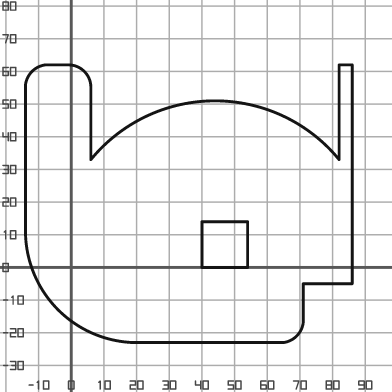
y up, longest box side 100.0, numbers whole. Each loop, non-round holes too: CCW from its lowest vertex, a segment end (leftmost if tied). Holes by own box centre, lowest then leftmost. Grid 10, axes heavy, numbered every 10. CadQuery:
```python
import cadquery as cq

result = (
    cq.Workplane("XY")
    .moveTo(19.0, -23.0)
    .lineTo(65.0, -23.0)
    .threePointArc((69.0, -21.0), (71.0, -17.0))
    .lineTo(71.0, -5.0)
    .lineTo(86.0, -5.0)
    .lineTo(86.0, 62.0)
    .lineTo(82.0, 62.0)
    .lineTo(82.0, 33.0)
    .threePointArc((44.0, 51.0), (6.0, 33.0))
    .lineTo(6.0, 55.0)
    .threePointArc((4.0, 60.0), (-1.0, 62.0))
    .lineTo(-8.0, 62.0)
    .threePointArc((-12.0, 60.0), (-14.0, 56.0))
    .lineTo(-14.0, 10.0)
    .threePointArc((-4.0, -13.0), (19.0, -23.0))
    .close()
    .moveTo(40.0, 0.0)
    .lineTo(54.0, 0.0)
    .lineTo(54.0, 14.0)
    .lineTo(40.0, 14.0)
    .close()
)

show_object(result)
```